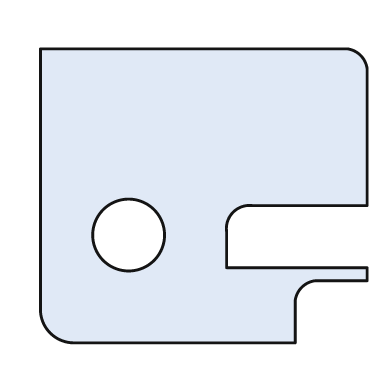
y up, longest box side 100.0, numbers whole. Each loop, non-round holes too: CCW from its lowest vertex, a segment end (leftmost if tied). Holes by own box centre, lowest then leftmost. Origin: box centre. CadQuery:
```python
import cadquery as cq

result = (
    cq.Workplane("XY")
    .moveTo(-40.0, -45.0)
    .lineTo(28.0, -45.0)
    .lineTo(28.0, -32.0)
    .threePointArc((30.0, -28.0), (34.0, -26.0))
    .lineTo(50.0, -26.0)
    .lineTo(50.0, -22.0)
    .lineTo(7.0, -22.0)
    .lineTo(7.0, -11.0)
    .threePointArc((9.0, -5.0), (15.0, -3.0))
    .lineTo(50.0, -3.0)
    .lineTo(50.0, 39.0)
    .threePointArc((48.0, 43.0), (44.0, 45.0))
    .lineTo(-50.0, 45.0)
    .lineTo(-50.0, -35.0)
    .threePointArc((-47.0, -42.0), (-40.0, -45.0))
    .close()
    .moveTo(-23.0, -12.0)
    .circle(11.0)
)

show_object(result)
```